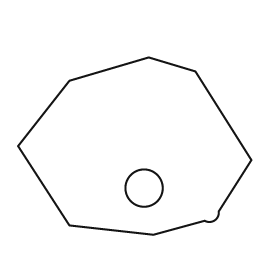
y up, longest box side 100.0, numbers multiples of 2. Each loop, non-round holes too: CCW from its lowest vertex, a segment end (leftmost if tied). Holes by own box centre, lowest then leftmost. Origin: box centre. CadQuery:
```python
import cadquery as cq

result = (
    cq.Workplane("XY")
    .moveTo(8.0, -38.0)
    .lineTo(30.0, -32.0)
    .threePointArc((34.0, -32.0), (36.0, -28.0))
    .lineTo(50.0, -6.0)
    .lineTo(26.0, 32.0)
    .lineTo(6.0, 38.0)
    .lineTo(-28.0, 28.0)
    .lineTo(-50.0, 0.0)
    .lineTo(-28.0, -34.0)
    .close()
    .moveTo(4.0, -18.0)
    .circle(8.0)
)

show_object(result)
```